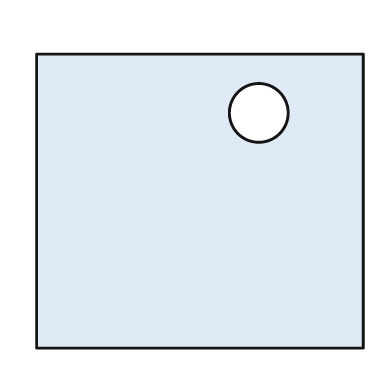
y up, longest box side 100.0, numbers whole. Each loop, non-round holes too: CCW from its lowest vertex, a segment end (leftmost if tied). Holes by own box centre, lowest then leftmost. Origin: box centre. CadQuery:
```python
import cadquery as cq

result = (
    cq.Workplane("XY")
    .moveTo(-50.0, -45.0)
    .lineTo(50.0, -45.0)
    .lineTo(50.0, 45.0)
    .lineTo(-50.0, 45.0)
    .close()
    .moveTo(18.0, 27.0)
    .circle(9.0)
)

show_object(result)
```